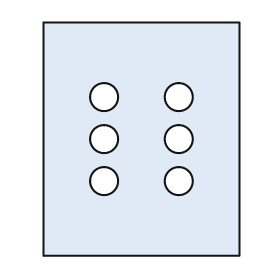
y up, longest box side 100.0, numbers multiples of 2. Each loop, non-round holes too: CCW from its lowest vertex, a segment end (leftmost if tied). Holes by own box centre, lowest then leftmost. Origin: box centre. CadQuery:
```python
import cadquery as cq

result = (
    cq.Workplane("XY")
    .moveTo(-42.0, -50.0)
    .lineTo(42.0, -50.0)
    .lineTo(42.0, 50.0)
    .lineTo(-42.0, 50.0)
    .close()
    .moveTo(-16.0, -18.0)
    .circle(6.0)
    .moveTo(16.0, -18.0)
    .circle(6.0)
    .moveTo(-16.0, 0.0)
    .circle(6.0)
    .moveTo(16.0, 0.0)
    .circle(6.0)
    .moveTo(-16.0, 18.0)
    .circle(6.0)
    .moveTo(16.0, 18.0)
    .circle(6.0)
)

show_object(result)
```